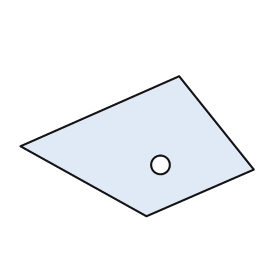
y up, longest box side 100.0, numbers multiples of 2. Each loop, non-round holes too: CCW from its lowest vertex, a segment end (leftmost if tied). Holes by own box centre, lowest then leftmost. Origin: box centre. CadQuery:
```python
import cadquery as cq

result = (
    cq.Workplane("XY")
    .moveTo(4.0, -30.0)
    .lineTo(50.0, -10.0)
    .lineTo(18.0, 30.0)
    .lineTo(-50.0, 0.0)
    .close()
    .moveTo(10.0, -8.0)
    .circle(4.0)
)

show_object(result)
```